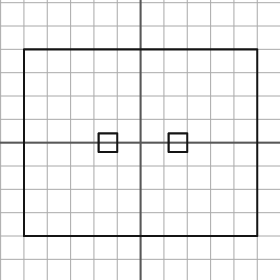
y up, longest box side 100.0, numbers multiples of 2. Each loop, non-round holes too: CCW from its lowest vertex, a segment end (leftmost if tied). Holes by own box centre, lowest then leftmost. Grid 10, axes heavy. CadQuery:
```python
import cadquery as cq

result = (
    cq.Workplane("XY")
    .moveTo(-50.0, -40.0)
    .lineTo(50.0, -40.0)
    .lineTo(50.0, 40.0)
    .lineTo(-50.0, 40.0)
    .close()
    .moveTo(-18.0, -4.0)
    .lineTo(-10.0, -4.0)
    .lineTo(-10.0, 4.0)
    .lineTo(-18.0, 4.0)
    .close()
    .moveTo(12.0, -4.0)
    .lineTo(20.0, -4.0)
    .lineTo(20.0, 4.0)
    .lineTo(12.0, 4.0)
    .close()
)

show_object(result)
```